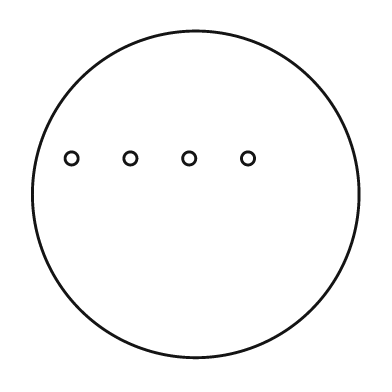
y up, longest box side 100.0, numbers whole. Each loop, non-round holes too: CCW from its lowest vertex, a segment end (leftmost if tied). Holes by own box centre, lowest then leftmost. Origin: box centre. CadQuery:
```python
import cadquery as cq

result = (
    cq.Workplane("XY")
    .moveTo(0.0, 0.0)
    .circle(50.0)
    .moveTo(-38.0, 11.0)
    .circle(2.0)
    .moveTo(-20.0, 11.0)
    .circle(2.0)
    .moveTo(-2.0, 11.0)
    .circle(2.0)
    .moveTo(16.0, 11.0)
    .circle(2.0)
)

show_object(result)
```